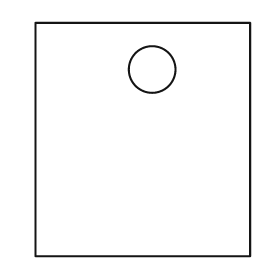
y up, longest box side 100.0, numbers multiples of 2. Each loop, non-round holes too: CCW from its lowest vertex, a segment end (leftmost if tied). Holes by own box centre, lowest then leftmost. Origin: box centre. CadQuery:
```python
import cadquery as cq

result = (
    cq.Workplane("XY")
    .moveTo(-46.0, -50.0)
    .lineTo(46.0, -50.0)
    .lineTo(46.0, 50.0)
    .lineTo(-46.0, 50.0)
    .close()
    .moveTo(4.0, 30.0)
    .circle(10.0)
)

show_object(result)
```